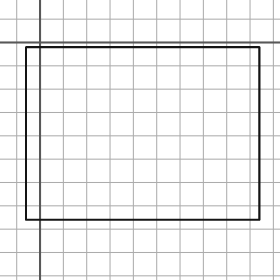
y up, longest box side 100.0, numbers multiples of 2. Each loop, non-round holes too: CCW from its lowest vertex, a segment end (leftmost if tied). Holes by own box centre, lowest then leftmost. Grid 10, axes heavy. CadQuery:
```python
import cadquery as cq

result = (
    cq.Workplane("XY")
    .moveTo(-6.0, -76.0)
    .lineTo(94.0, -76.0)
    .lineTo(94.0, -2.0)
    .lineTo(-6.0, -2.0)
    .close()
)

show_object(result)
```